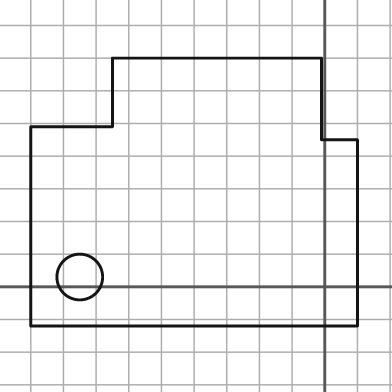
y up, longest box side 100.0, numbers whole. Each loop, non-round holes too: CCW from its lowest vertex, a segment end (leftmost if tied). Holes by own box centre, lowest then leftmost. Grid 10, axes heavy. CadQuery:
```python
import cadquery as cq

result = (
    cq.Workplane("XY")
    .moveTo(-90.0, -12.0)
    .lineTo(10.0, -12.0)
    .lineTo(10.0, 45.0)
    .lineTo(-1.0, 45.0)
    .lineTo(-1.0, 70.0)
    .lineTo(-65.0, 70.0)
    .lineTo(-65.0, 49.0)
    .lineTo(-90.0, 49.0)
    .close()
    .moveTo(-75.0, 3.0)
    .circle(7.0)
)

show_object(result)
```